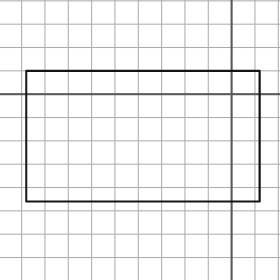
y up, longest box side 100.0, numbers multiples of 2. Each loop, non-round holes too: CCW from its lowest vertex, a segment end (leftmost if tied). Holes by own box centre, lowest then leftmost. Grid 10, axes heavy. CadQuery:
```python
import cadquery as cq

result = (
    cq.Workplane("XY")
    .moveTo(-88.0, -46.0)
    .lineTo(12.0, -46.0)
    .lineTo(12.0, 10.0)
    .lineTo(-88.0, 10.0)
    .close()
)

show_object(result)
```